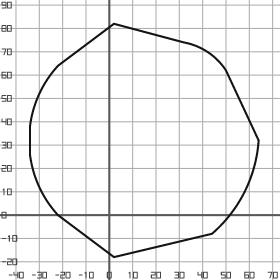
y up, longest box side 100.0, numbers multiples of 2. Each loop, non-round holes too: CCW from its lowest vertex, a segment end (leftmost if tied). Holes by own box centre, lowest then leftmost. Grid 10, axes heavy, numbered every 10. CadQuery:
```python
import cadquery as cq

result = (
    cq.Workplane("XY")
    .moveTo(2.0, -18.0)
    .lineTo(44.0, -8.0)
    .threePointArc((58.0, 10.0), (64.0, 32.0))
    .lineTo(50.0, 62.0)
    .threePointArc((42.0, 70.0), (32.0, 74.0))
    .lineTo(2.0, 82.0)
    .lineTo(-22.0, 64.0)
    .threePointArc((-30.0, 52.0), (-34.0, 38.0))
    .lineTo(-34.0, 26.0)
    .threePointArc((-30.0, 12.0), (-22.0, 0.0))
    .close()
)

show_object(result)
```